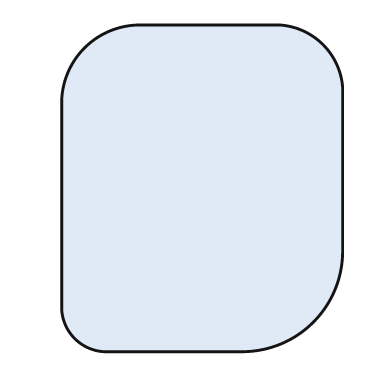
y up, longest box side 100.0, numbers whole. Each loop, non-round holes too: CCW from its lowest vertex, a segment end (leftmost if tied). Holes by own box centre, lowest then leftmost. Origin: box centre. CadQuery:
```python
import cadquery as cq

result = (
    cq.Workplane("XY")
    .moveTo(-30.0, -50.0)
    .lineTo(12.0, -50.0)
    .threePointArc((34.0, -41.0), (43.0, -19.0))
    .lineTo(43.0, 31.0)
    .threePointArc((37.0, 44.0), (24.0, 50.0))
    .lineTo(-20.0, 50.0)
    .threePointArc((-36.0, 43.0), (-43.0, 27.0))
    .lineTo(-43.0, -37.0)
    .threePointArc((-39.0, -46.0), (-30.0, -50.0))
    .close()
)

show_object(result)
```